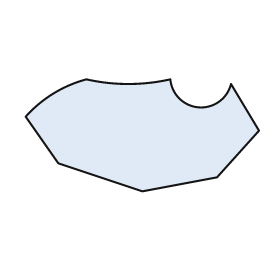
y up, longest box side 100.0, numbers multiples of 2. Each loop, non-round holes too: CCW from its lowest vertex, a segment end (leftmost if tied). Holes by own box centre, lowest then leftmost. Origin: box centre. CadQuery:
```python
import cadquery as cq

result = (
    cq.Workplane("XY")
    .moveTo(0.0, -24.0)
    .lineTo(32.0, -18.0)
    .lineTo(50.0, 2.0)
    .lineTo(38.0, 22.0)
    .threePointArc((24.0, 12.0), (12.0, 24.0))
    .threePointArc((-6.0, 22.0), (-24.0, 24.0))
    .threePointArc((-38.0, 18.0), (-50.0, 8.0))
    .lineTo(-36.0, -12.0)
    .close()
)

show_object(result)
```